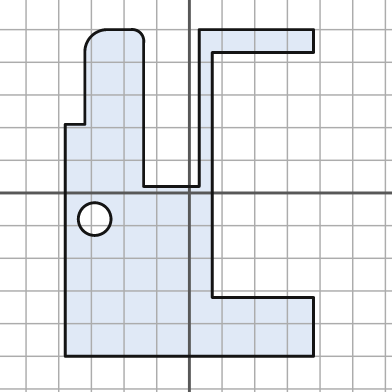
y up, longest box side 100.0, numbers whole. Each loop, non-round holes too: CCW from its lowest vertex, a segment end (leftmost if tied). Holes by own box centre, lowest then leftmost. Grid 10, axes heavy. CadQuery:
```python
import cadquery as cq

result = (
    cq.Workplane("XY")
    .moveTo(-38.0, -50.0)
    .lineTo(38.0, -50.0)
    .lineTo(38.0, -32.0)
    .lineTo(7.0, -32.0)
    .lineTo(7.0, 43.0)
    .lineTo(38.0, 43.0)
    .lineTo(38.0, 50.0)
    .lineTo(3.0, 50.0)
    .lineTo(3.0, 2.0)
    .lineTo(-14.0, 2.0)
    .lineTo(-14.0, 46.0)
    .threePointArc((-15.0, 49.0), (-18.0, 50.0))
    .lineTo(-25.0, 50.0)
    .threePointArc((-30.0, 48.0), (-32.0, 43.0))
    .lineTo(-32.0, 21.0)
    .lineTo(-38.0, 21.0)
    .close()
    .moveTo(-29.0, -8.0)
    .circle(5.0)
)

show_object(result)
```